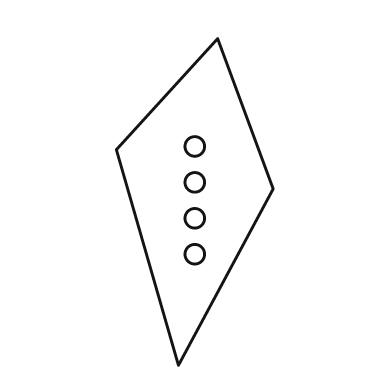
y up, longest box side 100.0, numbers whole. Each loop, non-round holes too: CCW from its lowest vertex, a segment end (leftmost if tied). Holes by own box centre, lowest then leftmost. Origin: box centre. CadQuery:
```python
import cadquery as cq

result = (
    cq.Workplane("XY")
    .moveTo(-5.0, -50.0)
    .lineTo(24.0, 4.0)
    .lineTo(7.0, 50.0)
    .lineTo(-24.0, 16.0)
    .close()
    .moveTo(0.0, -16.0)
    .circle(3.0)
    .moveTo(0.0, -5.0)
    .circle(3.0)
    .moveTo(0.0, 6.0)
    .circle(3.0)
    .moveTo(0.0, 17.0)
    .circle(3.0)
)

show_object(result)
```